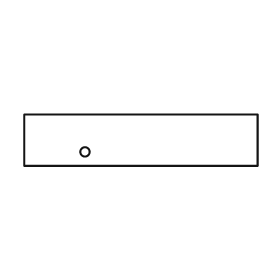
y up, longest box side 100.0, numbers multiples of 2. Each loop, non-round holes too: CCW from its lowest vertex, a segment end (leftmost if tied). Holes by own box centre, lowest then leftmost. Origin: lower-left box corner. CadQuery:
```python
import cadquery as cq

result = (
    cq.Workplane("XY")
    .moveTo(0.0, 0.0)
    .lineTo(100.0, 0.0)
    .lineTo(100.0, 22.0)
    .lineTo(0.0, 22.0)
    .close()
    .moveTo(26.0, 6.0)
    .circle(2.0)
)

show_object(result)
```